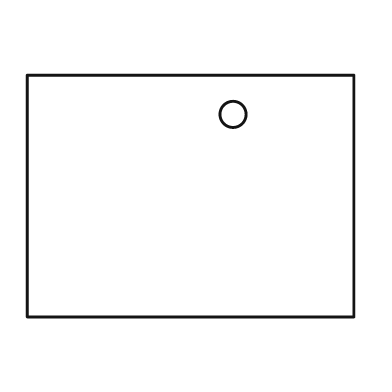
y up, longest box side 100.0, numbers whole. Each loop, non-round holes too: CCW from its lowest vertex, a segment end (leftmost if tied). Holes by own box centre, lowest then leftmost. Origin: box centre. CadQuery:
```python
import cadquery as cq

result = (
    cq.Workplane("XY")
    .moveTo(-50.0, -37.0)
    .lineTo(50.0, -37.0)
    .lineTo(50.0, 37.0)
    .lineTo(-50.0, 37.0)
    .close()
    .moveTo(13.0, 25.0)
    .circle(4.0)
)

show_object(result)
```